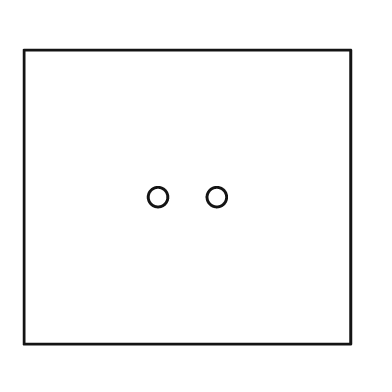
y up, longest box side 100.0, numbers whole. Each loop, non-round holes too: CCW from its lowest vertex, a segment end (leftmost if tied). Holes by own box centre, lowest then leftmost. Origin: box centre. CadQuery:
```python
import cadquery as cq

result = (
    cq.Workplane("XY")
    .moveTo(-50.0, -45.0)
    .lineTo(50.0, -45.0)
    .lineTo(50.0, 45.0)
    .lineTo(-50.0, 45.0)
    .close()
    .moveTo(-9.0, 0.0)
    .circle(3.0)
    .moveTo(9.0, 0.0)
    .circle(3.0)
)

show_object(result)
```